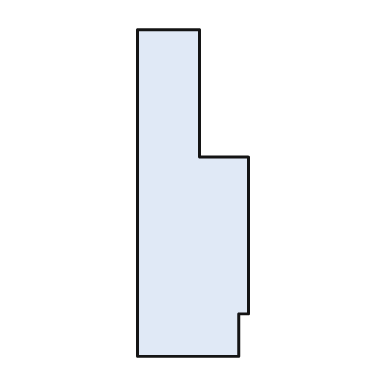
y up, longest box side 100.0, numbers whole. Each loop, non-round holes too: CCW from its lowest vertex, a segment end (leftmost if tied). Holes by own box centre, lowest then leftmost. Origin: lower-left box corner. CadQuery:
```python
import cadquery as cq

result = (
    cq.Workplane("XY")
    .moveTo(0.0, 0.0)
    .lineTo(31.0, 0.0)
    .lineTo(31.0, 13.0)
    .lineTo(34.0, 13.0)
    .lineTo(34.0, 61.0)
    .lineTo(19.0, 61.0)
    .lineTo(19.0, 100.0)
    .lineTo(0.0, 100.0)
    .close()
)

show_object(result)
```